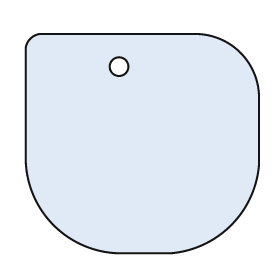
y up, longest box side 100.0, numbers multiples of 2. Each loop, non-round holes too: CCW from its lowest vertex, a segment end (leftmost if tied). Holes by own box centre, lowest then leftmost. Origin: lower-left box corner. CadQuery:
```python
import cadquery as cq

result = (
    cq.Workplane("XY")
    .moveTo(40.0, 0.0)
    .lineTo(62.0, 0.0)
    .threePointArc((88.0, 12.0), (100.0, 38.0))
    .lineTo(100.0, 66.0)
    .threePointArc((92.0, 86.0), (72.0, 94.0))
    .lineTo(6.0, 94.0)
    .threePointArc((2.0, 92.0), (0.0, 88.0))
    .lineTo(0.0, 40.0)
    .threePointArc((12.0, 12.0), (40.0, 0.0))
    .close()
    .moveTo(40.0, 80.0)
    .circle(4.0)
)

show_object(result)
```